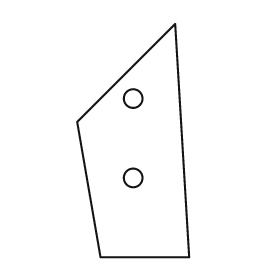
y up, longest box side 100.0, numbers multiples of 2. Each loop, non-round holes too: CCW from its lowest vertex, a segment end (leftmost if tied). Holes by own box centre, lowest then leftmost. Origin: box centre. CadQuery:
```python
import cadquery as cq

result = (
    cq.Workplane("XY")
    .moveTo(-14.0, -50.0)
    .lineTo(24.0, -50.0)
    .lineTo(18.0, 50.0)
    .lineTo(-24.0, 8.0)
    .close()
    .moveTo(0.0, -16.0)
    .circle(4.0)
    .moveTo(0.0, 18.0)
    .circle(4.0)
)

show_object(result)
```